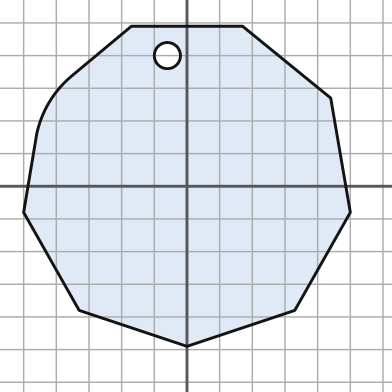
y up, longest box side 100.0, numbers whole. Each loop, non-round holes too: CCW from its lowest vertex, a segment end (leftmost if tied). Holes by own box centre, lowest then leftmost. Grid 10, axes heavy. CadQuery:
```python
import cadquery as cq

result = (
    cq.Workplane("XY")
    .moveTo(0.0, -49.0)
    .lineTo(33.0, -38.0)
    .lineTo(50.0, -8.0)
    .lineTo(44.0, 27.0)
    .lineTo(17.0, 49.0)
    .lineTo(-17.0, 49.0)
    .lineTo(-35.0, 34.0)
    .threePointArc((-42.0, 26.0), (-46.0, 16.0))
    .lineTo(-50.0, -8.0)
    .lineTo(-33.0, -38.0)
    .close()
    .moveTo(-6.0, 40.0)
    .circle(4.0)
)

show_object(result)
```